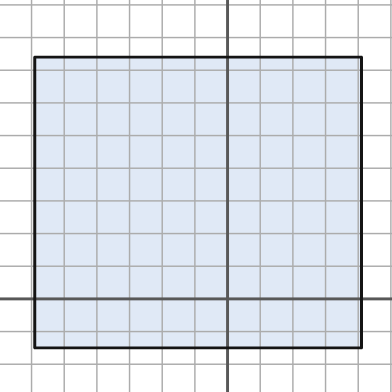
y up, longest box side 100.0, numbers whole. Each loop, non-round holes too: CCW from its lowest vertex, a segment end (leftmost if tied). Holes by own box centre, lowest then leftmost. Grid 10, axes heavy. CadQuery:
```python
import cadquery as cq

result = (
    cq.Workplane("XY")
    .moveTo(-59.0, -15.0)
    .lineTo(41.0, -15.0)
    .lineTo(41.0, 74.0)
    .lineTo(-59.0, 74.0)
    .close()
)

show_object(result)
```